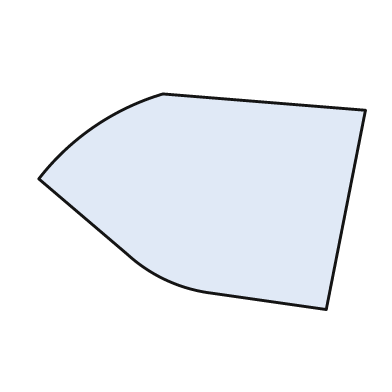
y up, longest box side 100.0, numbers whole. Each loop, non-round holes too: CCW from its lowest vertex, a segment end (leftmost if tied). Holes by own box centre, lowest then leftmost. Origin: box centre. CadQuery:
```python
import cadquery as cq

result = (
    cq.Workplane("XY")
    .moveTo(38.0, -33.0)
    .lineTo(50.0, 28.0)
    .lineTo(-12.0, 33.0)
    .threePointArc((-33.0, 23.0), (-50.0, 7.0))
    .lineTo(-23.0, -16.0)
    .threePointArc((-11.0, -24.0), (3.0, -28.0))
    .close()
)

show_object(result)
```